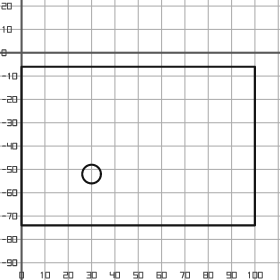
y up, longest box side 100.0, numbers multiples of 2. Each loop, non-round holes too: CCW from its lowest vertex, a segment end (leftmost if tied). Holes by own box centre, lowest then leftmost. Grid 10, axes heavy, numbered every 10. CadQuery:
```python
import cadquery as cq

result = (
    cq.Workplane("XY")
    .moveTo(0.0, -74.0)
    .lineTo(100.0, -74.0)
    .lineTo(100.0, -6.0)
    .lineTo(0.0, -6.0)
    .close()
    .moveTo(30.0, -52.0)
    .circle(4.0)
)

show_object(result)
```